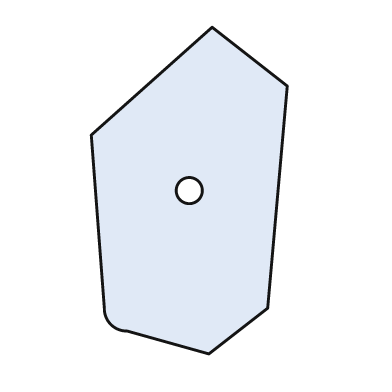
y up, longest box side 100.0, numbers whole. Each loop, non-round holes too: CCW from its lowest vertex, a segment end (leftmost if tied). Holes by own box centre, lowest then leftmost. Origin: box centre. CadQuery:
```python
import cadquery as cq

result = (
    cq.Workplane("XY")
    .moveTo(6.0, -50.0)
    .lineTo(24.0, -36.0)
    .lineTo(30.0, 32.0)
    .lineTo(7.0, 50.0)
    .lineTo(-30.0, 17.0)
    .lineTo(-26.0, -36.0)
    .threePointArc((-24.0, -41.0), (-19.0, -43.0))
    .close()
    .moveTo(0.0, 0.0)
    .circle(4.0)
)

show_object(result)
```